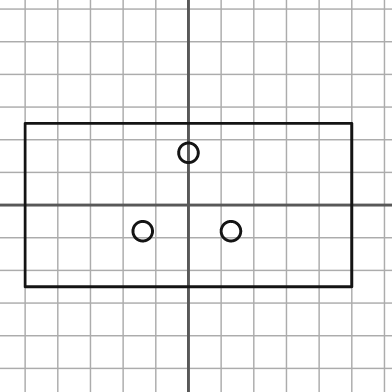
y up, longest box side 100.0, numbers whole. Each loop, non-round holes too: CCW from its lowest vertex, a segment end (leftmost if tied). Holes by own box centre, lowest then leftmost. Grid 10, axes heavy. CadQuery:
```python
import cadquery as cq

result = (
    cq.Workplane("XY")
    .moveTo(-50.0, -25.0)
    .lineTo(50.0, -25.0)
    .lineTo(50.0, 25.0)
    .lineTo(-50.0, 25.0)
    .close()
    .moveTo(-14.0, -8.0)
    .circle(3.0)
    .moveTo(13.0, -8.0)
    .circle(3.0)
    .moveTo(0.0, 16.0)
    .circle(3.0)
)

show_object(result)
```